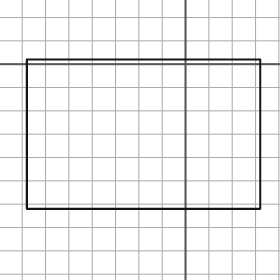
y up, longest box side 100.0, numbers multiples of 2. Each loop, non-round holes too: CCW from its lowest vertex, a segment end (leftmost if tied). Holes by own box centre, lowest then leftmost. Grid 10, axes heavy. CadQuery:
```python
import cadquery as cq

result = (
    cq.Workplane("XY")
    .moveTo(-68.0, -62.0)
    .lineTo(32.0, -62.0)
    .lineTo(32.0, 2.0)
    .lineTo(-68.0, 2.0)
    .close()
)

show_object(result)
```